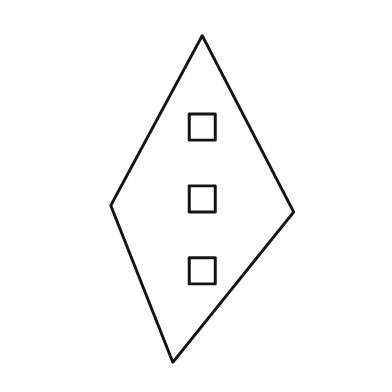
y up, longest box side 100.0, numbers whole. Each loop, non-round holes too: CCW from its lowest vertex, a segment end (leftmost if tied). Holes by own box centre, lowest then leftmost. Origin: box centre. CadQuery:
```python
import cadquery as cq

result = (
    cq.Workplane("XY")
    .moveTo(-9.0, -50.0)
    .lineTo(28.0, -4.0)
    .lineTo(0.0, 50.0)
    .lineTo(-28.0, -2.0)
    .close()
    .moveTo(-4.0, -26.0)
    .lineTo(4.0, -26.0)
    .lineTo(4.0, -18.0)
    .lineTo(-4.0, -18.0)
    .close()
    .moveTo(-4.0, -4.0)
    .lineTo(4.0, -4.0)
    .lineTo(4.0, 4.0)
    .lineTo(-4.0, 4.0)
    .close()
    .moveTo(-4.0, 18.0)
    .lineTo(4.0, 18.0)
    .lineTo(4.0, 26.0)
    .lineTo(-4.0, 26.0)
    .close()
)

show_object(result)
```